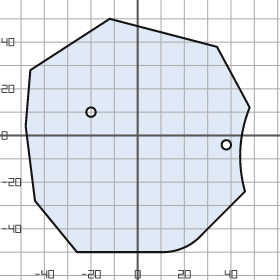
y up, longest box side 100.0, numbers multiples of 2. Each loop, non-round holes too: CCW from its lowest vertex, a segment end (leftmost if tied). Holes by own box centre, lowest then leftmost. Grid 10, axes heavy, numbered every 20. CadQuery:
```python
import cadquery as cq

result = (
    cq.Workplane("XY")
    .moveTo(-26.0, -50.0)
    .lineTo(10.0, -50.0)
    .threePointArc((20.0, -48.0), (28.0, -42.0))
    .lineTo(46.0, -24.0)
    .threePointArc((44.0, -6.0), (48.0, 12.0))
    .lineTo(34.0, 38.0)
    .lineTo(-12.0, 50.0)
    .lineTo(-46.0, 28.0)
    .lineTo(-48.0, 4.0)
    .lineTo(-44.0, -28.0)
    .close()
    .moveTo(38.0, -4.0)
    .circle(2.0)
    .moveTo(-20.0, 10.0)
    .circle(2.0)
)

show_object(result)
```